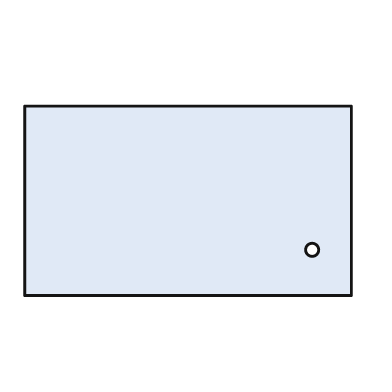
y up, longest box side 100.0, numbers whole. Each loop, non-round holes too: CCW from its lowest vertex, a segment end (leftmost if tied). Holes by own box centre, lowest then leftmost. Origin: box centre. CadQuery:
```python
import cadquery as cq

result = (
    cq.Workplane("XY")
    .moveTo(-50.0, -29.0)
    .lineTo(50.0, -29.0)
    .lineTo(50.0, 29.0)
    .lineTo(-50.0, 29.0)
    .close()
    .moveTo(38.0, -15.0)
    .circle(2.0)
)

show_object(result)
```